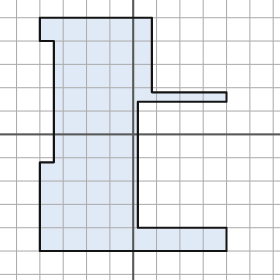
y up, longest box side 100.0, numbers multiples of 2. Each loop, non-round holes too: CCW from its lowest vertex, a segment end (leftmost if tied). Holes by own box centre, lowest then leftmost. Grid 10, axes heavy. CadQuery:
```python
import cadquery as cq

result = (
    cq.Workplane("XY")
    .moveTo(-40.0, -50.0)
    .lineTo(40.0, -50.0)
    .lineTo(40.0, -40.0)
    .lineTo(2.0, -40.0)
    .lineTo(2.0, 14.0)
    .lineTo(40.0, 14.0)
    .lineTo(40.0, 18.0)
    .lineTo(8.0, 18.0)
    .lineTo(8.0, 50.0)
    .lineTo(-40.0, 50.0)
    .lineTo(-40.0, 40.0)
    .lineTo(-34.0, 40.0)
    .lineTo(-34.0, -12.0)
    .lineTo(-40.0, -12.0)
    .close()
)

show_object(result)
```